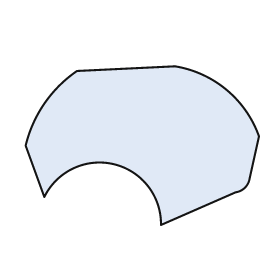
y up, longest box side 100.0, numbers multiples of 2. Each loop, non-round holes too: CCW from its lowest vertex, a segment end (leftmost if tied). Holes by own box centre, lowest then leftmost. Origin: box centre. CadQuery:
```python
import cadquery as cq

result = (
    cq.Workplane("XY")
    .moveTo(8.0, -34.0)
    .lineTo(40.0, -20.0)
    .threePointArc((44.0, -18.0), (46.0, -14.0))
    .lineTo(50.0, 4.0)
    .threePointArc((36.0, 24.0), (14.0, 34.0))
    .lineTo(-28.0, 32.0)
    .threePointArc((-42.0, 18.0), (-50.0, 0.0))
    .lineTo(-42.0, -22.0)
    .threePointArc((-12.0, -8.0), (8.0, -34.0))
    .close()
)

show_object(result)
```